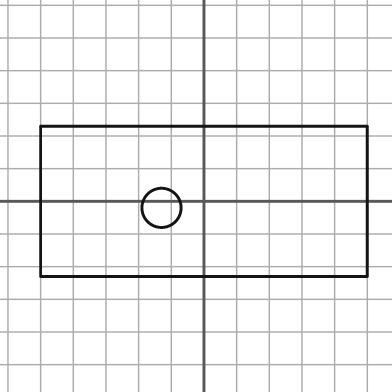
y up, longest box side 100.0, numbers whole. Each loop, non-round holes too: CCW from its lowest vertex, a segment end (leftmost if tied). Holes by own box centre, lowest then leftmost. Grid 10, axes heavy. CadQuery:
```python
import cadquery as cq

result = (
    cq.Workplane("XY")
    .moveTo(-50.0, -23.0)
    .lineTo(50.0, -23.0)
    .lineTo(50.0, 23.0)
    .lineTo(-50.0, 23.0)
    .close()
    .moveTo(-13.0, -2.0)
    .circle(6.0)
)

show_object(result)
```